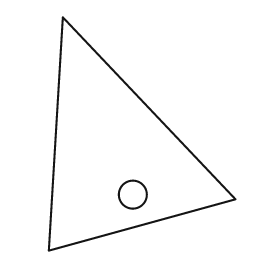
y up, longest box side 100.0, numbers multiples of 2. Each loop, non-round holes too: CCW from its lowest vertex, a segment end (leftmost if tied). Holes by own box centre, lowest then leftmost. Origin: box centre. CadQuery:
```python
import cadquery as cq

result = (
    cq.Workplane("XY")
    .moveTo(-40.0, -50.0)
    .lineTo(40.0, -28.0)
    .lineTo(-34.0, 50.0)
    .close()
    .moveTo(-4.0, -26.0)
    .circle(6.0)
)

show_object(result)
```